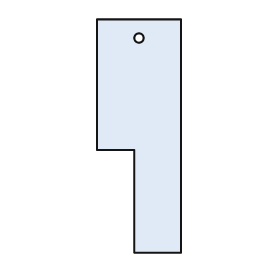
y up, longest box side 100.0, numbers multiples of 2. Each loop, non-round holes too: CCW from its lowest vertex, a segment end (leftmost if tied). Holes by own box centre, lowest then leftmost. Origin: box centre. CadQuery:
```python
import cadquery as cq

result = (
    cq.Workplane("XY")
    .moveTo(-2.0, -50.0)
    .lineTo(18.0, -50.0)
    .lineTo(18.0, 50.0)
    .lineTo(-18.0, 50.0)
    .lineTo(-18.0, -6.0)
    .lineTo(-2.0, -6.0)
    .close()
    .moveTo(0.0, 42.0)
    .circle(2.0)
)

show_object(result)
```